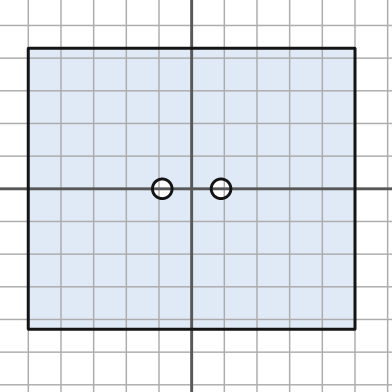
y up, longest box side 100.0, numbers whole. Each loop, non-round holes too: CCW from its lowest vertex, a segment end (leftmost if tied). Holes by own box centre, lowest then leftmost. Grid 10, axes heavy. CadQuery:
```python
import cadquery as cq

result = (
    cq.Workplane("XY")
    .moveTo(-50.0, -43.0)
    .lineTo(50.0, -43.0)
    .lineTo(50.0, 43.0)
    .lineTo(-50.0, 43.0)
    .close()
    .moveTo(-9.0, 0.0)
    .circle(3.0)
    .moveTo(9.0, 0.0)
    .circle(3.0)
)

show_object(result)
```